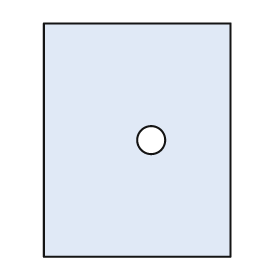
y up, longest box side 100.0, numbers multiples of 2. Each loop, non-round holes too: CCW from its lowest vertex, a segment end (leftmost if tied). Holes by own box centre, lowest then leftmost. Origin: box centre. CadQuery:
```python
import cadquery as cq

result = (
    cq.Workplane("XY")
    .moveTo(-40.0, -50.0)
    .lineTo(40.0, -50.0)
    .lineTo(40.0, 50.0)
    .lineTo(-40.0, 50.0)
    .close()
    .moveTo(6.0, 0.0)
    .circle(6.0)
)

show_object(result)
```